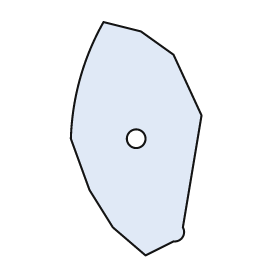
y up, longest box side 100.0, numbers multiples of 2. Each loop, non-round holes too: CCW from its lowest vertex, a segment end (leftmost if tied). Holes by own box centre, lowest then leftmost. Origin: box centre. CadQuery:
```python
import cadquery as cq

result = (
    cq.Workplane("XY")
    .moveTo(4.0, -50.0)
    .lineTo(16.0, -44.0)
    .threePointArc((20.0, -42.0), (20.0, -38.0))
    .lineTo(28.0, 10.0)
    .lineTo(16.0, 36.0)
    .lineTo(2.0, 46.0)
    .lineTo(-14.0, 50.0)
    .threePointArc((-24.0, 26.0), (-28.0, 0.0))
    .lineTo(-20.0, -22.0)
    .lineTo(-10.0, -38.0)
    .close()
    .moveTo(0.0, 0.0)
    .circle(4.0)
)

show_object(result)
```